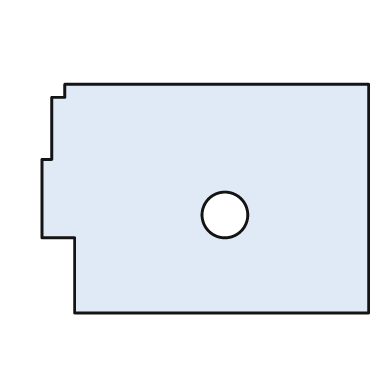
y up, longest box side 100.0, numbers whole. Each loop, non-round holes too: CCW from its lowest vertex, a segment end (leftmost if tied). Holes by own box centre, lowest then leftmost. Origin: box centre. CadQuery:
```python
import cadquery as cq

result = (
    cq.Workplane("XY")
    .moveTo(-40.0, -35.0)
    .lineTo(50.0, -35.0)
    .lineTo(50.0, 35.0)
    .lineTo(-43.0, 35.0)
    .lineTo(-43.0, 31.0)
    .lineTo(-47.0, 31.0)
    .lineTo(-47.0, 12.0)
    .lineTo(-50.0, 12.0)
    .lineTo(-50.0, -12.0)
    .lineTo(-40.0, -12.0)
    .close()
    .moveTo(6.0, -5.0)
    .circle(7.0)
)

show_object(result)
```